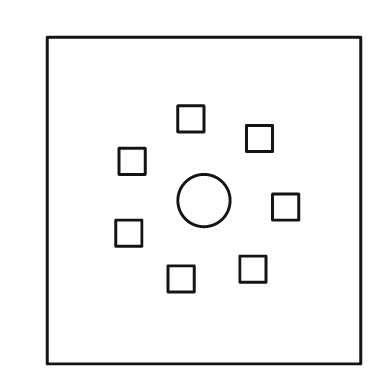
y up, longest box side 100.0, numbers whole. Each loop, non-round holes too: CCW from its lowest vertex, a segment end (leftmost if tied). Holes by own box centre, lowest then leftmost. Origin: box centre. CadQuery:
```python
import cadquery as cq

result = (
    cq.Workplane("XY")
    .moveTo(-48.0, -50.0)
    .lineTo(48.0, -50.0)
    .lineTo(48.0, 50.0)
    .lineTo(-48.0, 50.0)
    .close()
    .moveTo(-11.0, -28.0)
    .lineTo(-3.0, -28.0)
    .lineTo(-3.0, -20.0)
    .lineTo(-11.0, -20.0)
    .close()
    .moveTo(11.0, -25.0)
    .lineTo(19.0, -25.0)
    .lineTo(19.0, -17.0)
    .lineTo(11.0, -17.0)
    .close()
    .moveTo(-27.0, -14.0)
    .lineTo(-19.0, -14.0)
    .lineTo(-19.0, -6.0)
    .lineTo(-27.0, -6.0)
    .close()
    .moveTo(21.0, -6.0)
    .lineTo(29.0, -6.0)
    .lineTo(29.0, 2.0)
    .lineTo(21.0, 2.0)
    .close()
    .moveTo(0.0, 0.0)
    .circle(8.0)
    .moveTo(-26.0, 8.0)
    .lineTo(-18.0, 8.0)
    .lineTo(-18.0, 16.0)
    .lineTo(-26.0, 16.0)
    .close()
    .moveTo(13.0, 15.0)
    .lineTo(21.0, 15.0)
    .lineTo(21.0, 23.0)
    .lineTo(13.0, 23.0)
    .close()
    .moveTo(-8.0, 21.0)
    .lineTo(0.0, 21.0)
    .lineTo(0.0, 29.0)
    .lineTo(-8.0, 29.0)
    .close()
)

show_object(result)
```